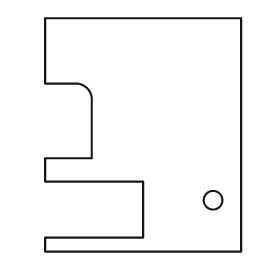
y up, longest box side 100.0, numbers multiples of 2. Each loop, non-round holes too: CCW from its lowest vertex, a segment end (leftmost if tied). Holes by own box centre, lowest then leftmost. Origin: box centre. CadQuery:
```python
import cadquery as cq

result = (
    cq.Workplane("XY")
    .moveTo(-42.0, -50.0)
    .lineTo(42.0, -50.0)
    .lineTo(42.0, 50.0)
    .lineTo(-42.0, 50.0)
    .lineTo(-42.0, 22.0)
    .lineTo(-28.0, 22.0)
    .threePointArc((-24.0, 20.0), (-22.0, 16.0))
    .lineTo(-22.0, -10.0)
    .lineTo(-42.0, -10.0)
    .lineTo(-42.0, -20.0)
    .lineTo(0.0, -20.0)
    .lineTo(0.0, -44.0)
    .lineTo(-42.0, -44.0)
    .close()
    .moveTo(30.0, -28.0)
    .circle(4.0)
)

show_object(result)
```